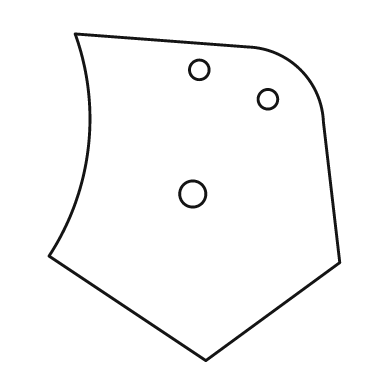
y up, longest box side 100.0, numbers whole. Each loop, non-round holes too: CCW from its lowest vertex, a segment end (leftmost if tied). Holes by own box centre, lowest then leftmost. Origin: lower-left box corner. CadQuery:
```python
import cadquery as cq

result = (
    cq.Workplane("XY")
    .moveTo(48.0, 0.0)
    .lineTo(89.0, 30.0)
    .lineTo(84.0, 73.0)
    .threePointArc((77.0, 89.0), (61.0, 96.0))
    .lineTo(8.0, 100.0)
    .threePointArc((12.0, 65.0), (0.0, 32.0))
    .close()
    .moveTo(44.0, 51.0)
    .circle(4.0)
    .moveTo(67.0, 80.0)
    .circle(3.0)
    .moveTo(46.0, 89.0)
    .circle(3.0)
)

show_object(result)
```